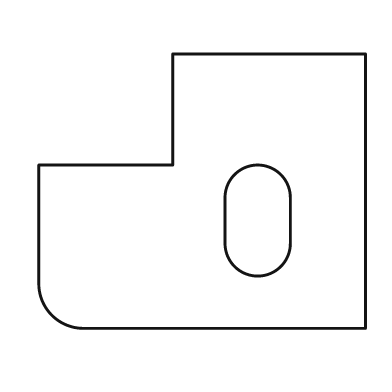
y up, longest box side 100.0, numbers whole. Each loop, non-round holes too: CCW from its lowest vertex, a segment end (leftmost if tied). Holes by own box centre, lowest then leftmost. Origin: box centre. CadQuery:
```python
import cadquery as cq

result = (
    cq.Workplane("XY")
    .moveTo(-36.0, -42.0)
    .lineTo(50.0, -42.0)
    .lineTo(50.0, 42.0)
    .lineTo(-9.0, 42.0)
    .lineTo(-9.0, 8.0)
    .lineTo(-50.0, 8.0)
    .lineTo(-50.0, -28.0)
    .threePointArc((-46.0, -38.0), (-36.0, -42.0))
    .close()
    .moveTo(7.0, -16.0)
    .threePointArc((17.0, -26.0), (27.0, -16.0))
    .lineTo(27.0, -2.0)
    .threePointArc((17.0, 8.0), (7.0, -2.0))
    .close()
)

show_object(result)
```